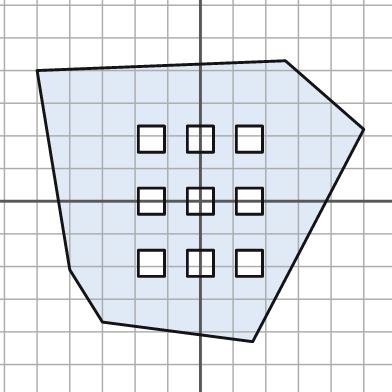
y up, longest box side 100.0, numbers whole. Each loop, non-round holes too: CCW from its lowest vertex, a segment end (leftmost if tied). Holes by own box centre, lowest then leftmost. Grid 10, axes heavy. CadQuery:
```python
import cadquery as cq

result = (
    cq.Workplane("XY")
    .moveTo(16.0, -43.0)
    .lineTo(50.0, 22.0)
    .lineTo(26.0, 43.0)
    .lineTo(-50.0, 40.0)
    .lineTo(-40.0, -21.0)
    .lineTo(-30.0, -37.0)
    .close()
    .moveTo(-19.0, -23.0)
    .lineTo(-11.0, -23.0)
    .lineTo(-11.0, -15.0)
    .lineTo(-19.0, -15.0)
    .close()
    .moveTo(-4.0, -23.0)
    .lineTo(4.0, -23.0)
    .lineTo(4.0, -15.0)
    .lineTo(-4.0, -15.0)
    .close()
    .moveTo(11.0, -23.0)
    .lineTo(19.0, -23.0)
    .lineTo(19.0, -15.0)
    .lineTo(11.0, -15.0)
    .close()
    .moveTo(-19.0, -4.0)
    .lineTo(-11.0, -4.0)
    .lineTo(-11.0, 4.0)
    .lineTo(-19.0, 4.0)
    .close()
    .moveTo(-4.0, -4.0)
    .lineTo(4.0, -4.0)
    .lineTo(4.0, 4.0)
    .lineTo(-4.0, 4.0)
    .close()
    .moveTo(11.0, -4.0)
    .lineTo(19.0, -4.0)
    .lineTo(19.0, 4.0)
    .lineTo(11.0, 4.0)
    .close()
    .moveTo(-19.0, 15.0)
    .lineTo(-11.0, 15.0)
    .lineTo(-11.0, 23.0)
    .lineTo(-19.0, 23.0)
    .close()
    .moveTo(-4.0, 15.0)
    .lineTo(4.0, 15.0)
    .lineTo(4.0, 23.0)
    .lineTo(-4.0, 23.0)
    .close()
    .moveTo(11.0, 15.0)
    .lineTo(19.0, 15.0)
    .lineTo(19.0, 23.0)
    .lineTo(11.0, 23.0)
    .close()
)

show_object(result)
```